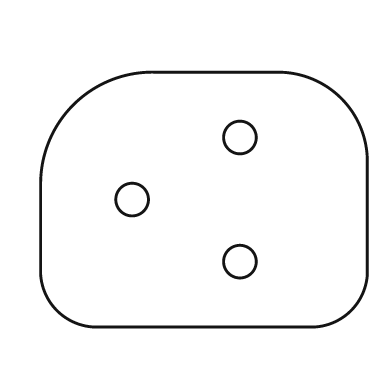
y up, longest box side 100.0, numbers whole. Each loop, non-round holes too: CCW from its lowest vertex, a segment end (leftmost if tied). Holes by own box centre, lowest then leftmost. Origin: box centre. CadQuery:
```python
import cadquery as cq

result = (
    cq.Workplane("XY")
    .moveTo(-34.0, -39.0)
    .lineTo(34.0, -39.0)
    .threePointArc((45.0, -34.0), (50.0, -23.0))
    .lineTo(50.0, 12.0)
    .threePointArc((42.0, 31.0), (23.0, 39.0))
    .lineTo(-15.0, 39.0)
    .threePointArc((-40.0, 29.0), (-50.0, 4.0))
    .lineTo(-50.0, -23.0)
    .threePointArc((-45.0, -34.0), (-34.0, -39.0))
    .close()
    .moveTo(11.0, -19.0)
    .circle(5.0)
    .moveTo(-22.0, 0.0)
    .circle(5.0)
    .moveTo(11.0, 19.0)
    .circle(5.0)
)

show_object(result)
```